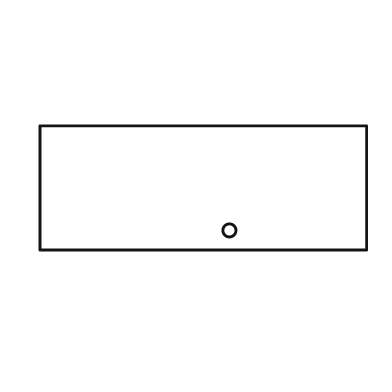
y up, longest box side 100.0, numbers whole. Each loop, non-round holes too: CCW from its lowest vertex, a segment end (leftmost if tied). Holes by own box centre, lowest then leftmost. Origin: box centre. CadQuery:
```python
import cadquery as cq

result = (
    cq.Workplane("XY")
    .moveTo(-50.0, -19.0)
    .lineTo(50.0, -19.0)
    .lineTo(50.0, 19.0)
    .lineTo(-50.0, 19.0)
    .close()
    .moveTo(8.0, -13.0)
    .circle(2.0)
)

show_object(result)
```